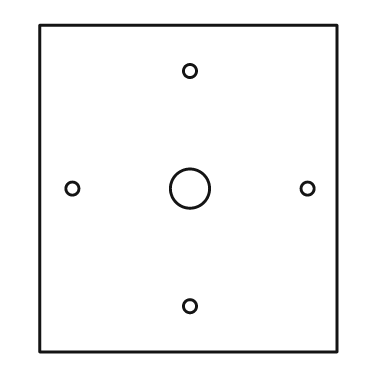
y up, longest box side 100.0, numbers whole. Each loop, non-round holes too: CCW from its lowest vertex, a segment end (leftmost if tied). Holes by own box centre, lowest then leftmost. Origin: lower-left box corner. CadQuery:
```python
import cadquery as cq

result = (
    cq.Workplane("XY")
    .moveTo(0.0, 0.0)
    .lineTo(91.0, 0.0)
    .lineTo(91.0, 100.0)
    .lineTo(0.0, 100.0)
    .close()
    .moveTo(46.0, 14.0)
    .circle(2.0)
    .moveTo(10.0, 50.0)
    .circle(2.0)
    .moveTo(46.0, 50.0)
    .circle(6.0)
    .moveTo(82.0, 50.0)
    .circle(2.0)
    .moveTo(46.0, 86.0)
    .circle(2.0)
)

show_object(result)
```